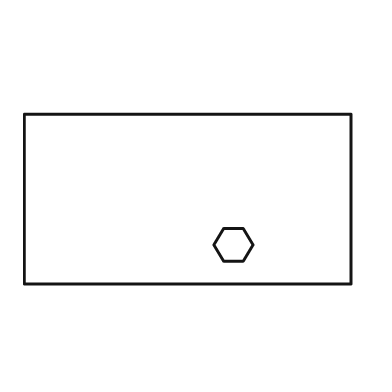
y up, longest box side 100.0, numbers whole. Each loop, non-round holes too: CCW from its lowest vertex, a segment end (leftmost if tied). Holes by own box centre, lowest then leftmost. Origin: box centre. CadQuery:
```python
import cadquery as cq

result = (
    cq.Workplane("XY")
    .moveTo(-50.0, -26.0)
    .lineTo(50.0, -26.0)
    .lineTo(50.0, 26.0)
    .lineTo(-50.0, 26.0)
    .close()
    .moveTo(11.0, -19.0)
    .lineTo(17.0, -19.0)
    .lineTo(20.0, -14.0)
    .lineTo(17.0, -9.0)
    .lineTo(11.0, -9.0)
    .lineTo(8.0, -14.0)
    .close()
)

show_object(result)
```